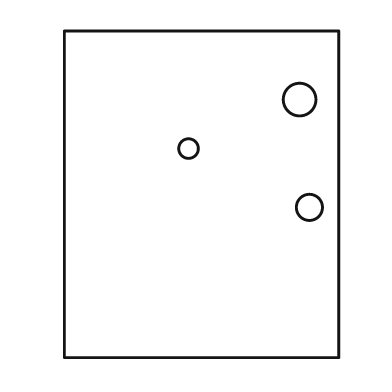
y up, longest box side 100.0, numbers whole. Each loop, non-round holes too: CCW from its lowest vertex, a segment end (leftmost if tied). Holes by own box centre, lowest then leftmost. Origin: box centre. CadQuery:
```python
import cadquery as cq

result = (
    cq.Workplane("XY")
    .moveTo(-42.0, -50.0)
    .lineTo(42.0, -50.0)
    .lineTo(42.0, 50.0)
    .lineTo(-42.0, 50.0)
    .close()
    .moveTo(33.0, -4.0)
    .circle(4.0)
    .moveTo(-4.0, 14.0)
    .circle(3.0)
    .moveTo(30.0, 29.0)
    .circle(5.0)
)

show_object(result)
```